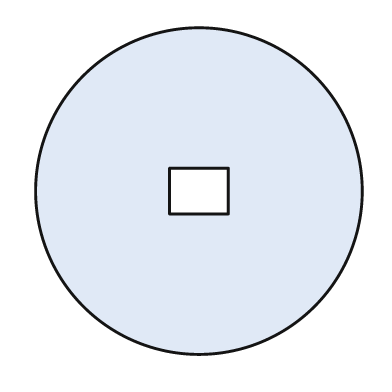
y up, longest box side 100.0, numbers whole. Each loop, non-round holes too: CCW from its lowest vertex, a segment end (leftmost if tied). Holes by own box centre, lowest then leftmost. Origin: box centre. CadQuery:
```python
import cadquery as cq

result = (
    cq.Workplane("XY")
    .moveTo(0.0, 0.0)
    .circle(50.0)
    .moveTo(-9.0, -7.0)
    .lineTo(9.0, -7.0)
    .lineTo(9.0, 7.0)
    .lineTo(-9.0, 7.0)
    .close()
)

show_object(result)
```